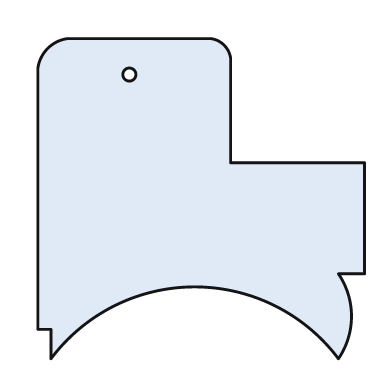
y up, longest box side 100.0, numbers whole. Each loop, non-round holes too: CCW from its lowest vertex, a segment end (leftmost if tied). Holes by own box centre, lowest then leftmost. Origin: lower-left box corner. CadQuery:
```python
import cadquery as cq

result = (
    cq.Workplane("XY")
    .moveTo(4.0, 0.0)
    .threePointArc((48.0, 22.0), (92.0, 0.0))
    .threePointArc((96.0, 13.0), (92.0, 26.0))
    .lineTo(100.0, 26.0)
    .lineTo(100.0, 60.0)
    .lineTo(59.0, 60.0)
    .lineTo(59.0, 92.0)
    .threePointArc((57.0, 96.0), (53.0, 98.0))
    .lineTo(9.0, 98.0)
    .threePointArc((3.0, 95.0), (0.0, 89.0))
    .lineTo(0.0, 9.0)
    .lineTo(4.0, 9.0)
    .close()
    .moveTo(28.0, 87.0)
    .circle(2.0)
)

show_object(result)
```